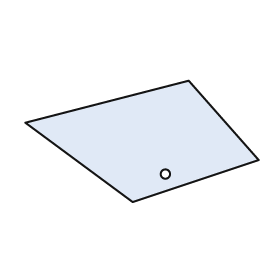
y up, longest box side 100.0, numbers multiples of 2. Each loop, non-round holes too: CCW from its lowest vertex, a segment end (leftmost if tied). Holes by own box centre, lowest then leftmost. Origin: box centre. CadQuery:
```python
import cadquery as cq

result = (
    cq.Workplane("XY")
    .moveTo(-4.0, -26.0)
    .lineTo(50.0, -8.0)
    .lineTo(20.0, 26.0)
    .lineTo(-50.0, 8.0)
    .close()
    .moveTo(10.0, -14.0)
    .circle(2.0)
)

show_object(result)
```